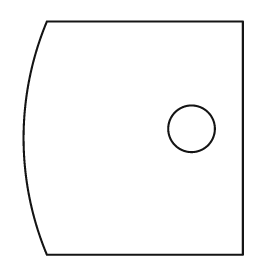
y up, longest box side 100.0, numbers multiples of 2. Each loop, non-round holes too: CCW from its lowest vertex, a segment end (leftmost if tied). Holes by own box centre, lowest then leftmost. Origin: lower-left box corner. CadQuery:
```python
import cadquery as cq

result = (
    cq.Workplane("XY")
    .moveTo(10.0, 0.0)
    .lineTo(94.0, 0.0)
    .lineTo(94.0, 100.0)
    .lineTo(10.0, 100.0)
    .threePointArc((0.0, 50.0), (10.0, 0.0))
    .close()
    .moveTo(72.0, 54.0)
    .circle(10.0)
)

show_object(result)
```